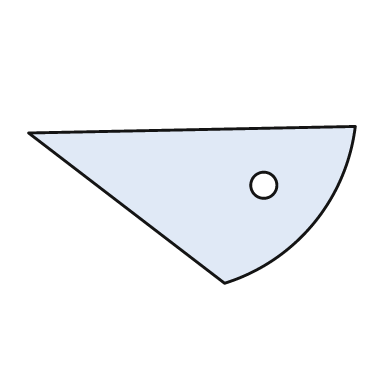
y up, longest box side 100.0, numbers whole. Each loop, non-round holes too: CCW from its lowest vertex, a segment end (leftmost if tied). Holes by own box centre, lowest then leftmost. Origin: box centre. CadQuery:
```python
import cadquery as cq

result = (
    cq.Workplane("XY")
    .moveTo(10.0, -24.0)
    .threePointArc((37.0, -6.0), (50.0, 24.0))
    .lineTo(-50.0, 22.0)
    .close()
    .moveTo(22.0, 6.0)
    .circle(4.0)
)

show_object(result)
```